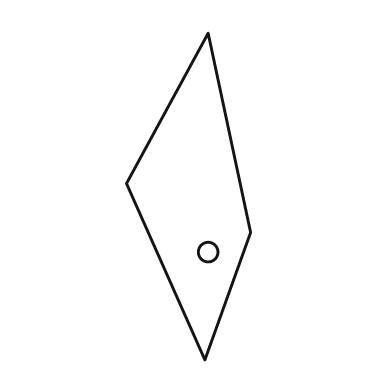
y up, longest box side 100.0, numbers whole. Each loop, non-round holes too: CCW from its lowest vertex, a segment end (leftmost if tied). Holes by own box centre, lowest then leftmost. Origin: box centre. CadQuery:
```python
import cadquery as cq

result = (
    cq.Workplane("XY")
    .moveTo(5.0, -50.0)
    .lineTo(19.0, -11.0)
    .lineTo(6.0, 50.0)
    .lineTo(-19.0, 4.0)
    .close()
    .moveTo(6.0, -17.0)
    .circle(3.0)
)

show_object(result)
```